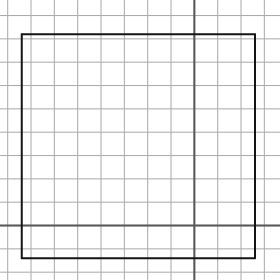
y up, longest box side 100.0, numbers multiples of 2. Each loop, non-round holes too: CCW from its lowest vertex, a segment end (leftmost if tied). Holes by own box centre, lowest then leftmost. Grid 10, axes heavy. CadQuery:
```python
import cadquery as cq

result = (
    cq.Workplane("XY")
    .moveTo(-74.0, -14.0)
    .lineTo(26.0, -14.0)
    .lineTo(26.0, 82.0)
    .lineTo(-74.0, 82.0)
    .close()
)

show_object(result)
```